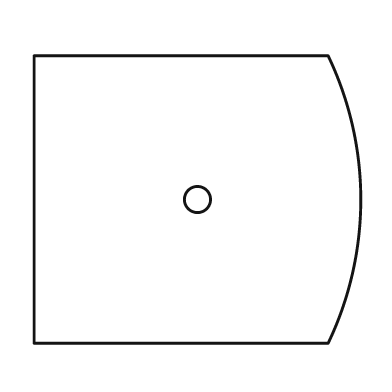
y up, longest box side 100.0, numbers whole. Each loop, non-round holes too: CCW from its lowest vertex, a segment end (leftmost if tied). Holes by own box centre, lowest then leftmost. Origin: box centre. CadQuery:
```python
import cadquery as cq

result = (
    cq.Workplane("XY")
    .moveTo(-50.0, -44.0)
    .lineTo(40.0, -44.0)
    .threePointArc((50.0, 0.0), (40.0, 44.0))
    .lineTo(-50.0, 44.0)
    .close()
    .moveTo(0.0, 0.0)
    .circle(4.0)
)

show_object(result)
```